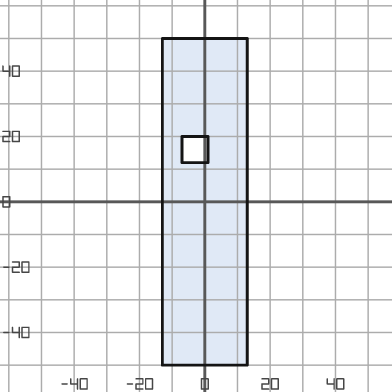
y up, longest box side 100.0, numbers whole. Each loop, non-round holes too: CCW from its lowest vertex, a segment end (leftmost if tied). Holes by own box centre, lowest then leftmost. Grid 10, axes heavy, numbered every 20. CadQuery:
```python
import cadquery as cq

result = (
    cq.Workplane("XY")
    .moveTo(-13.0, -50.0)
    .lineTo(13.0, -50.0)
    .lineTo(13.0, 50.0)
    .lineTo(-13.0, 50.0)
    .close()
    .moveTo(-7.0, 12.0)
    .lineTo(1.0, 12.0)
    .lineTo(1.0, 20.0)
    .lineTo(-7.0, 20.0)
    .close()
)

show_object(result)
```